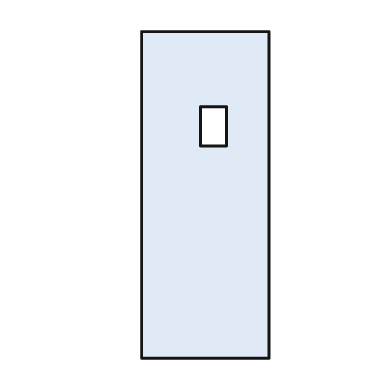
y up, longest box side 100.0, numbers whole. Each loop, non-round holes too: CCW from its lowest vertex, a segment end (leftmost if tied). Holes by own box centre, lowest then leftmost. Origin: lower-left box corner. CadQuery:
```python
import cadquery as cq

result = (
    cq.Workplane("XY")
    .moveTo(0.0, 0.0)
    .lineTo(39.0, 0.0)
    .lineTo(39.0, 100.0)
    .lineTo(0.0, 100.0)
    .close()
    .moveTo(18.0, 65.0)
    .lineTo(26.0, 65.0)
    .lineTo(26.0, 77.0)
    .lineTo(18.0, 77.0)
    .close()
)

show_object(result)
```